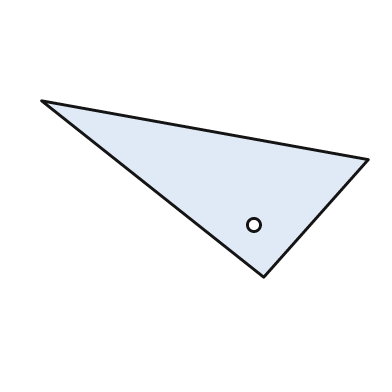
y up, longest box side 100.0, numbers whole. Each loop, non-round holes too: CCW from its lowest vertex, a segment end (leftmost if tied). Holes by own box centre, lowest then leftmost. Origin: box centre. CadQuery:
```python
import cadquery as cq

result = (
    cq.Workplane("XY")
    .moveTo(18.0, -27.0)
    .lineTo(50.0, 9.0)
    .lineTo(-50.0, 27.0)
    .close()
    .moveTo(15.0, -11.0)
    .circle(2.0)
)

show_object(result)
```